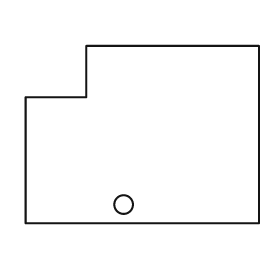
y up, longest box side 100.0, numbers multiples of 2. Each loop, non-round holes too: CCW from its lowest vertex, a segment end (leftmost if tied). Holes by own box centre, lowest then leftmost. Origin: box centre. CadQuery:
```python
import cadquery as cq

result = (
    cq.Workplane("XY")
    .moveTo(-50.0, -38.0)
    .lineTo(50.0, -38.0)
    .lineTo(50.0, 38.0)
    .lineTo(-24.0, 38.0)
    .lineTo(-24.0, 16.0)
    .lineTo(-50.0, 16.0)
    .close()
    .moveTo(-8.0, -30.0)
    .circle(4.0)
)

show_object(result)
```